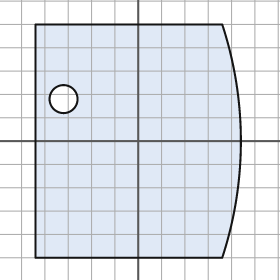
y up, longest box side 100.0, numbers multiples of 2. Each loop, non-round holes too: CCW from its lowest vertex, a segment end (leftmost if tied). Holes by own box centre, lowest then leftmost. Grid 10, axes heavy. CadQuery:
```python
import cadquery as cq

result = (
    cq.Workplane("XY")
    .moveTo(-44.0, -50.0)
    .lineTo(36.0, -50.0)
    .threePointArc((44.0, 0.0), (36.0, 50.0))
    .lineTo(-44.0, 50.0)
    .close()
    .moveTo(-32.0, 18.0)
    .circle(6.0)
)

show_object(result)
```